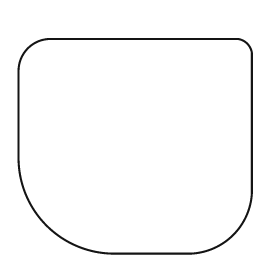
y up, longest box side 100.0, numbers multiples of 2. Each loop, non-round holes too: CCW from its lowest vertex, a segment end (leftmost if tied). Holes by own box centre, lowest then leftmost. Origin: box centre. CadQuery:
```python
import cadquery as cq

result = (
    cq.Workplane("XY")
    .moveTo(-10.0, -46.0)
    .lineTo(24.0, -46.0)
    .threePointArc((42.0, -38.0), (50.0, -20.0))
    .lineTo(50.0, 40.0)
    .threePointArc((48.0, 44.0), (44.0, 46.0))
    .lineTo(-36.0, 46.0)
    .threePointArc((-46.0, 42.0), (-50.0, 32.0))
    .lineTo(-50.0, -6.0)
    .threePointArc((-38.0, -34.0), (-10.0, -46.0))
    .close()
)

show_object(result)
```